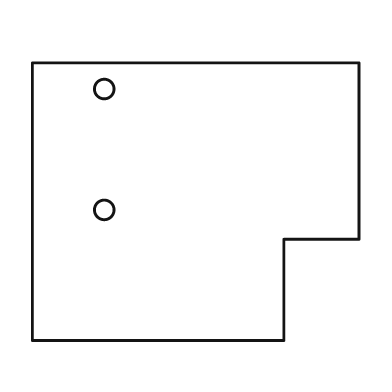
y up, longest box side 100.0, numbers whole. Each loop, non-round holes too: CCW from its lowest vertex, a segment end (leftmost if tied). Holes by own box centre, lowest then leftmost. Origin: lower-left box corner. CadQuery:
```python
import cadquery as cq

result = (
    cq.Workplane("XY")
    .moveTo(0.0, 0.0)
    .lineTo(77.0, 0.0)
    .lineTo(77.0, 31.0)
    .lineTo(100.0, 31.0)
    .lineTo(100.0, 85.0)
    .lineTo(0.0, 85.0)
    .close()
    .moveTo(22.0, 40.0)
    .circle(3.0)
    .moveTo(22.0, 77.0)
    .circle(3.0)
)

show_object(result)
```